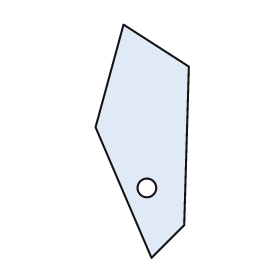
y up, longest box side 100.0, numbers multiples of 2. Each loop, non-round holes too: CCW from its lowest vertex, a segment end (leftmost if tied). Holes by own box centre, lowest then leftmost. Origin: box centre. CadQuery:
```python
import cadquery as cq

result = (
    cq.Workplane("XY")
    .moveTo(4.0, -50.0)
    .lineTo(18.0, -36.0)
    .lineTo(20.0, 32.0)
    .lineTo(-8.0, 50.0)
    .lineTo(-20.0, 6.0)
    .close()
    .moveTo(2.0, -20.0)
    .circle(4.0)
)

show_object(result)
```